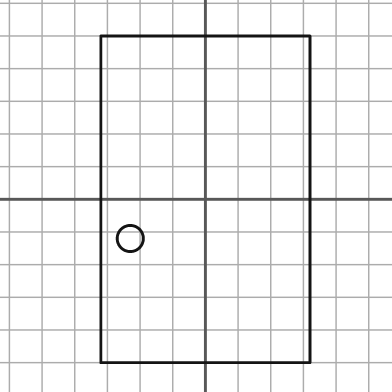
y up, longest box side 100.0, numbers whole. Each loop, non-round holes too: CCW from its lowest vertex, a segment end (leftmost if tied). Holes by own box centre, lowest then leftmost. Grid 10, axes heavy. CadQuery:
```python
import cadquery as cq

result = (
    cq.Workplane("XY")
    .moveTo(-32.0, -50.0)
    .lineTo(32.0, -50.0)
    .lineTo(32.0, 50.0)
    .lineTo(-32.0, 50.0)
    .close()
    .moveTo(-23.0, -12.0)
    .circle(4.0)
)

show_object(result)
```